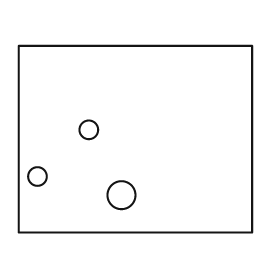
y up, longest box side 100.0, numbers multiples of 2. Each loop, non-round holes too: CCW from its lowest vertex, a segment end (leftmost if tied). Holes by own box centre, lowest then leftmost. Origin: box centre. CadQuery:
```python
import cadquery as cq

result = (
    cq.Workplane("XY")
    .moveTo(-50.0, -40.0)
    .lineTo(50.0, -40.0)
    .lineTo(50.0, 40.0)
    .lineTo(-50.0, 40.0)
    .close()
    .moveTo(-6.0, -24.0)
    .circle(6.0)
    .moveTo(-42.0, -16.0)
    .circle(4.0)
    .moveTo(-20.0, 4.0)
    .circle(4.0)
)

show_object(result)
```